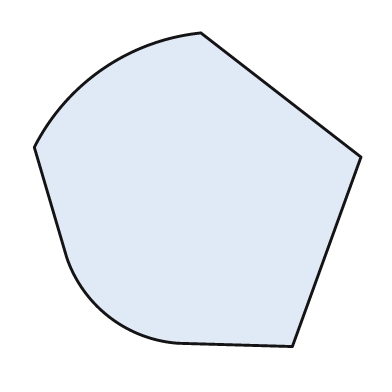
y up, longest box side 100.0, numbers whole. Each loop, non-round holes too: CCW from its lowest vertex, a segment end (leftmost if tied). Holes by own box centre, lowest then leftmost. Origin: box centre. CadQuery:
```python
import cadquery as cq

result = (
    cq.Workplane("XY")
    .moveTo(29.0, -48.0)
    .lineTo(50.0, 10.0)
    .lineTo(1.0, 48.0)
    .threePointArc((-29.0, 37.0), (-50.0, 13.0))
    .lineTo(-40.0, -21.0)
    .threePointArc((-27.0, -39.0), (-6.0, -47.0))
    .close()
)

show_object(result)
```